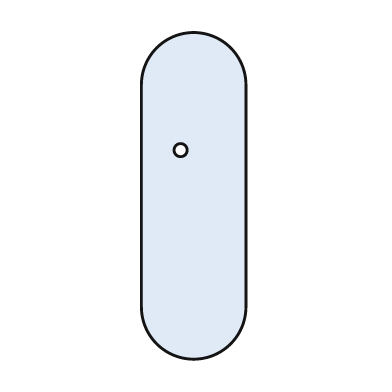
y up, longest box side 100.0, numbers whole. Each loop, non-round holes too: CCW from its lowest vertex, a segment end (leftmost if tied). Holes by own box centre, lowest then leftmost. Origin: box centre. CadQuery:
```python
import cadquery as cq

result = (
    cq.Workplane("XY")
    .moveTo(-16.0, -34.0)
    .threePointArc((0.0, -50.0), (16.0, -34.0))
    .lineTo(16.0, 34.0)
    .threePointArc((0.0, 50.0), (-16.0, 34.0))
    .close()
    .moveTo(-4.0, 14.0)
    .circle(2.0)
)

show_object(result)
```